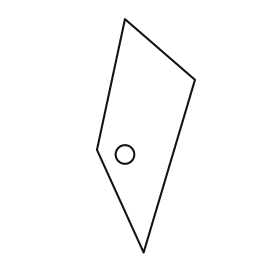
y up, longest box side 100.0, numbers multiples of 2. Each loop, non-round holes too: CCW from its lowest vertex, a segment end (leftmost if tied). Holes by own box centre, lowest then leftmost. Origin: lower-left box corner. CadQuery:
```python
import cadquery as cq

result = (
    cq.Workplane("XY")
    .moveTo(20.0, 0.0)
    .lineTo(42.0, 74.0)
    .lineTo(12.0, 100.0)
    .lineTo(0.0, 44.0)
    .close()
    .moveTo(12.0, 42.0)
    .circle(4.0)
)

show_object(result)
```